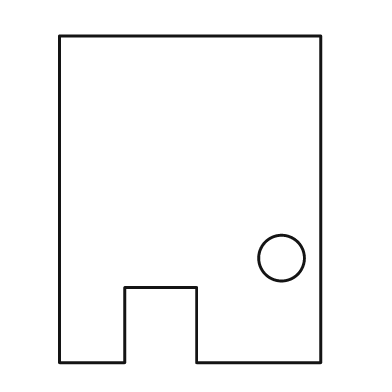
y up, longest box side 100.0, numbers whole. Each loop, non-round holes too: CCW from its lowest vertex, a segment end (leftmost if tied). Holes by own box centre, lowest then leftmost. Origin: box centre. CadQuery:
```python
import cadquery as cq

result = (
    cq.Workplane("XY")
    .moveTo(-40.0, -50.0)
    .lineTo(-20.0, -50.0)
    .lineTo(-20.0, -27.0)
    .lineTo(2.0, -27.0)
    .lineTo(2.0, -50.0)
    .lineTo(40.0, -50.0)
    .lineTo(40.0, 50.0)
    .lineTo(-40.0, 50.0)
    .close()
    .moveTo(28.0, -18.0)
    .circle(7.0)
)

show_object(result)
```